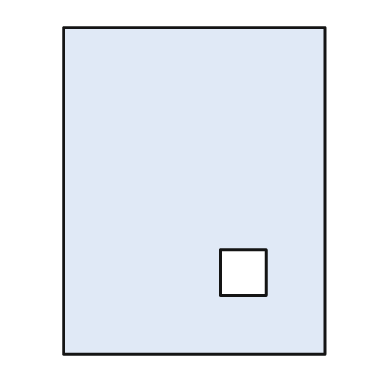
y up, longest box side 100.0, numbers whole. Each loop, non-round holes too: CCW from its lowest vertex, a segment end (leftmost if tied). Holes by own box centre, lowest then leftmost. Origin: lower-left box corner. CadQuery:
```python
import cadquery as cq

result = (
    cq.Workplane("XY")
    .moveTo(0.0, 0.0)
    .lineTo(80.0, 0.0)
    .lineTo(80.0, 100.0)
    .lineTo(0.0, 100.0)
    .close()
    .moveTo(48.0, 18.0)
    .lineTo(62.0, 18.0)
    .lineTo(62.0, 32.0)
    .lineTo(48.0, 32.0)
    .close()
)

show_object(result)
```